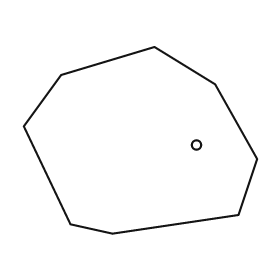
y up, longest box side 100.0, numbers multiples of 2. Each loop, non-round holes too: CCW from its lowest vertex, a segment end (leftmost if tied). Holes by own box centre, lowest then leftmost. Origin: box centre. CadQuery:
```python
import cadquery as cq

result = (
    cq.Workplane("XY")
    .moveTo(-12.0, -40.0)
    .lineTo(42.0, -32.0)
    .lineTo(50.0, -8.0)
    .lineTo(32.0, 24.0)
    .lineTo(6.0, 40.0)
    .lineTo(-34.0, 28.0)
    .lineTo(-50.0, 6.0)
    .lineTo(-30.0, -36.0)
    .close()
    .moveTo(24.0, -2.0)
    .circle(2.0)
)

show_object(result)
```